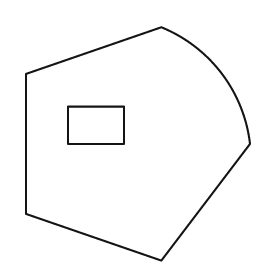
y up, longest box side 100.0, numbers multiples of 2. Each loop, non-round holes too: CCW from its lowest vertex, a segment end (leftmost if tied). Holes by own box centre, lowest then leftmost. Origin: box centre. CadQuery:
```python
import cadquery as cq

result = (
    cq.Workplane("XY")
    .moveTo(10.0, -50.0)
    .lineTo(48.0, 0.0)
    .threePointArc((36.0, 30.0), (10.0, 50.0))
    .lineTo(-48.0, 30.0)
    .lineTo(-48.0, -30.0)
    .close()
    .moveTo(-30.0, 0.0)
    .lineTo(-6.0, 0.0)
    .lineTo(-6.0, 16.0)
    .lineTo(-30.0, 16.0)
    .close()
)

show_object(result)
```